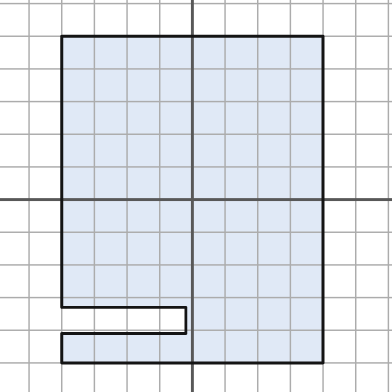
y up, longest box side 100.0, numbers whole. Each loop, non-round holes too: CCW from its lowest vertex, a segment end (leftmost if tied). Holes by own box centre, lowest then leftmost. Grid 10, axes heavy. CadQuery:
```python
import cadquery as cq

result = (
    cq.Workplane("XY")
    .moveTo(-40.0, -50.0)
    .lineTo(40.0, -50.0)
    .lineTo(40.0, 50.0)
    .lineTo(-40.0, 50.0)
    .lineTo(-40.0, -33.0)
    .lineTo(-2.0, -33.0)
    .lineTo(-2.0, -41.0)
    .lineTo(-40.0, -41.0)
    .close()
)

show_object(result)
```